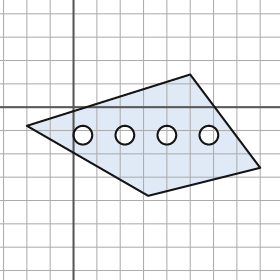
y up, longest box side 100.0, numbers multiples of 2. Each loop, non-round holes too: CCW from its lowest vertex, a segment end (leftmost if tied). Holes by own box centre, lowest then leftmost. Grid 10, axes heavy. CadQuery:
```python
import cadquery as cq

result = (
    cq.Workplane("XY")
    .moveTo(32.0, -38.0)
    .lineTo(80.0, -26.0)
    .lineTo(50.0, 14.0)
    .lineTo(-20.0, -8.0)
    .close()
    .moveTo(4.0, -12.0)
    .circle(4.0)
    .moveTo(22.0, -12.0)
    .circle(4.0)
    .moveTo(40.0, -12.0)
    .circle(4.0)
    .moveTo(58.0, -12.0)
    .circle(4.0)
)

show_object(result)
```